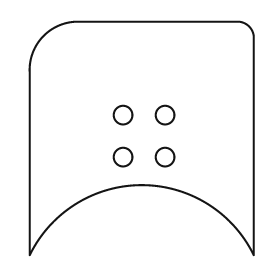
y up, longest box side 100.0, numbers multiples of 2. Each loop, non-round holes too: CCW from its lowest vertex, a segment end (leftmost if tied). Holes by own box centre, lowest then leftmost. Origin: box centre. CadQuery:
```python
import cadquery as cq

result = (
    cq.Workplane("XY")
    .moveTo(-48.0, -50.0)
    .threePointArc((0.0, -20.0), (48.0, -50.0))
    .lineTo(48.0, 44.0)
    .threePointArc((46.0, 48.0), (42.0, 50.0))
    .lineTo(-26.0, 50.0)
    .threePointArc((-42.0, 44.0), (-48.0, 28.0))
    .close()
    .moveTo(-8.0, -8.0)
    .circle(4.0)
    .moveTo(10.0, -8.0)
    .circle(4.0)
    .moveTo(-8.0, 10.0)
    .circle(4.0)
    .moveTo(10.0, 10.0)
    .circle(4.0)
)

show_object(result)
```